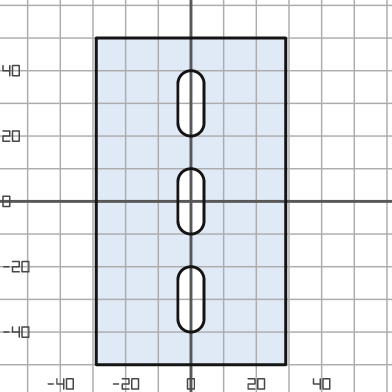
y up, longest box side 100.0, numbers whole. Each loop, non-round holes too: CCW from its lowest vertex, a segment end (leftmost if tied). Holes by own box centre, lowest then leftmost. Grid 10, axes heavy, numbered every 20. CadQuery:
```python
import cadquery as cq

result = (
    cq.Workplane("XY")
    .moveTo(-29.0, -50.0)
    .lineTo(29.0, -50.0)
    .lineTo(29.0, 50.0)
    .lineTo(-29.0, 50.0)
    .close()
    .moveTo(-4.0, -36.0)
    .threePointArc((0.0, -40.0), (4.0, -36.0))
    .lineTo(4.0, -24.0)
    .threePointArc((0.0, -20.0), (-4.0, -24.0))
    .close()
    .moveTo(-4.0, -6.0)
    .threePointArc((0.0, -10.0), (4.0, -6.0))
    .lineTo(4.0, 6.0)
    .threePointArc((0.0, 10.0), (-4.0, 6.0))
    .close()
    .moveTo(-4.0, 24.0)
    .threePointArc((0.0, 20.0), (4.0, 24.0))
    .lineTo(4.0, 36.0)
    .threePointArc((0.0, 40.0), (-4.0, 36.0))
    .close()
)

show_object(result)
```